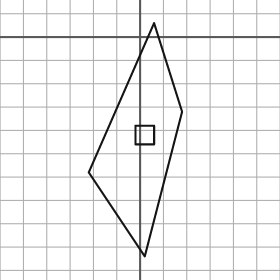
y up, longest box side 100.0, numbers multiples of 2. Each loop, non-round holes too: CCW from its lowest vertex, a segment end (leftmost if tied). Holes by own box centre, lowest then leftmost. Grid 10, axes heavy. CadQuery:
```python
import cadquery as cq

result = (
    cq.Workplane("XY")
    .moveTo(2.0, -94.0)
    .lineTo(18.0, -32.0)
    .lineTo(6.0, 6.0)
    .lineTo(-22.0, -58.0)
    .close()
    .moveTo(-2.0, -46.0)
    .lineTo(6.0, -46.0)
    .lineTo(6.0, -38.0)
    .lineTo(-2.0, -38.0)
    .close()
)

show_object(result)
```